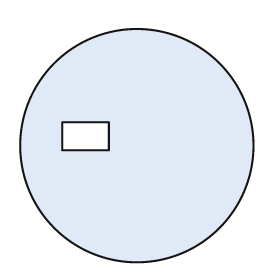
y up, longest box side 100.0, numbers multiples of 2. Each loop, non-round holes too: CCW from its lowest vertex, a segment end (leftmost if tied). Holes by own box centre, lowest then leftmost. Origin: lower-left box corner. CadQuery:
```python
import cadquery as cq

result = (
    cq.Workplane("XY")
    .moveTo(50.0, 50.0)
    .circle(50.0)
    .moveTo(18.0, 48.0)
    .lineTo(38.0, 48.0)
    .lineTo(38.0, 60.0)
    .lineTo(18.0, 60.0)
    .close()
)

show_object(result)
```